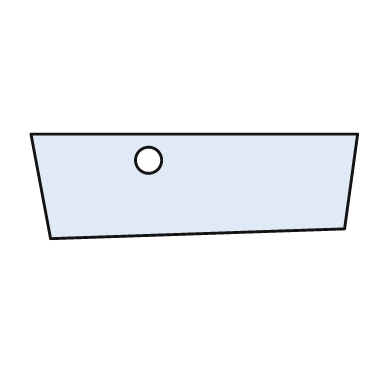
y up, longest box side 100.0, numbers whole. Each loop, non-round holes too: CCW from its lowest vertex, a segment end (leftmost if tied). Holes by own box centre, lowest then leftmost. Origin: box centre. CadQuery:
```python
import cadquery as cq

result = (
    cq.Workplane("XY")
    .moveTo(-44.0, -16.0)
    .lineTo(46.0, -13.0)
    .lineTo(50.0, 16.0)
    .lineTo(-50.0, 16.0)
    .close()
    .moveTo(-14.0, 8.0)
    .circle(4.0)
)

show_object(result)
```